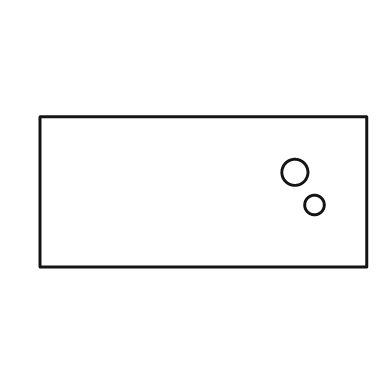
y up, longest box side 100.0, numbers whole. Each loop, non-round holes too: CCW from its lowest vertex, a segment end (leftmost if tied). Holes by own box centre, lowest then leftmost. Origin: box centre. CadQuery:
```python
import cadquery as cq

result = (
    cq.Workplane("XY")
    .moveTo(-50.0, -23.0)
    .lineTo(50.0, -23.0)
    .lineTo(50.0, 23.0)
    .lineTo(-50.0, 23.0)
    .close()
    .moveTo(34.0, -4.0)
    .circle(3.0)
    .moveTo(28.0, 6.0)
    .circle(4.0)
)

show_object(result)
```